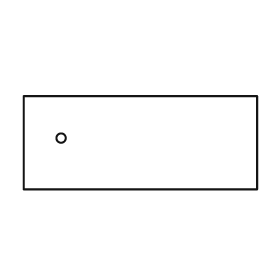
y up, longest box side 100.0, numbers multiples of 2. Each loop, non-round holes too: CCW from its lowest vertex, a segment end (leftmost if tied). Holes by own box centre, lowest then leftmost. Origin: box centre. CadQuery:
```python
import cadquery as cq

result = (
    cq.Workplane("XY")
    .moveTo(-50.0, -20.0)
    .lineTo(50.0, -20.0)
    .lineTo(50.0, 20.0)
    .lineTo(-50.0, 20.0)
    .close()
    .moveTo(-34.0, 2.0)
    .circle(2.0)
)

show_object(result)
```